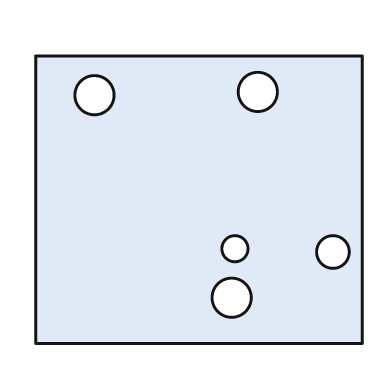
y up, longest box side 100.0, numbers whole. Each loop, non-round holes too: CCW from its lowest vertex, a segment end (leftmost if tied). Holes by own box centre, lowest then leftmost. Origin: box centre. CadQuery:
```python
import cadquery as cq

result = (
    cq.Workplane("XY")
    .moveTo(-50.0, -44.0)
    .lineTo(50.0, -44.0)
    .lineTo(50.0, 44.0)
    .lineTo(-50.0, 44.0)
    .close()
    .moveTo(10.0, -30.0)
    .circle(6.0)
    .moveTo(41.0, -16.0)
    .circle(5.0)
    .moveTo(11.0, -15.0)
    .circle(4.0)
    .moveTo(-32.0, 32.0)
    .circle(6.0)
    .moveTo(18.0, 33.0)
    .circle(6.0)
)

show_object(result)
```